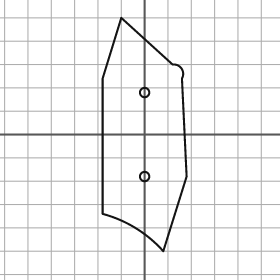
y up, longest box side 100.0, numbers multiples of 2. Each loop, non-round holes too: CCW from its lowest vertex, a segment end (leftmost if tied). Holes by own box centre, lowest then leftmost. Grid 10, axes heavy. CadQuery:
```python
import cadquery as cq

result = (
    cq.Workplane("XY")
    .moveTo(8.0, -50.0)
    .lineTo(18.0, -18.0)
    .lineTo(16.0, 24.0)
    .threePointArc((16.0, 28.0), (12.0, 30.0))
    .lineTo(-10.0, 50.0)
    .lineTo(-18.0, 24.0)
    .lineTo(-18.0, -34.0)
    .threePointArc((-4.0, -40.0), (8.0, -50.0))
    .close()
    .moveTo(0.0, -18.0)
    .circle(2.0)
    .moveTo(0.0, 18.0)
    .circle(2.0)
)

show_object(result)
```